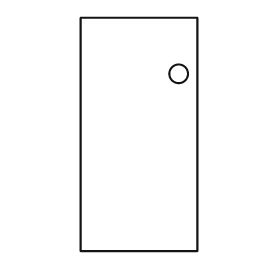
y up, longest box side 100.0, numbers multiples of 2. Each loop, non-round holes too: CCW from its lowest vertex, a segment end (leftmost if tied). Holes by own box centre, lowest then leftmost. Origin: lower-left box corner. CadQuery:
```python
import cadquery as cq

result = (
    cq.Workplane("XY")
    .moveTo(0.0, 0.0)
    .lineTo(50.0, 0.0)
    .lineTo(50.0, 100.0)
    .lineTo(0.0, 100.0)
    .close()
    .moveTo(42.0, 76.0)
    .circle(4.0)
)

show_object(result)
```